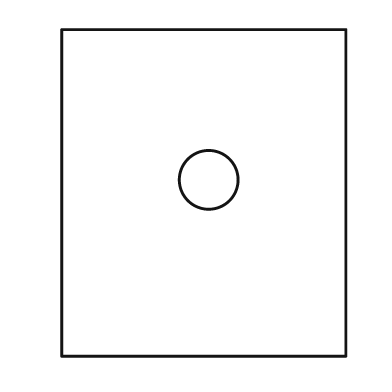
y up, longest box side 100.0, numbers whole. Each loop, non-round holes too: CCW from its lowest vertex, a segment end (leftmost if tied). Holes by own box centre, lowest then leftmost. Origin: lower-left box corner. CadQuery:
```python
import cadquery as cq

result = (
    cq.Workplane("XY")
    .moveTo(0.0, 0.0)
    .lineTo(87.0, 0.0)
    .lineTo(87.0, 100.0)
    .lineTo(0.0, 100.0)
    .close()
    .moveTo(45.0, 54.0)
    .circle(9.0)
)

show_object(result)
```